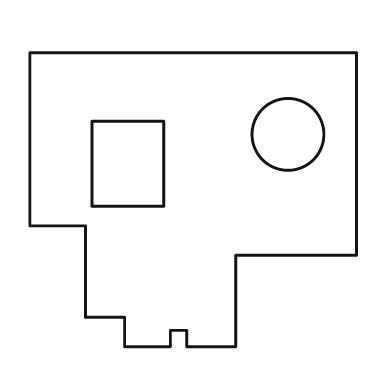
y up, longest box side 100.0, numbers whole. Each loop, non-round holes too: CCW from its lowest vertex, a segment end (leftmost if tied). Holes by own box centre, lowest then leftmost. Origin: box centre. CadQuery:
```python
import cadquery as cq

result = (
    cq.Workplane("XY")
    .moveTo(-21.0, -45.0)
    .lineTo(-7.0, -45.0)
    .lineTo(-7.0, -40.0)
    .lineTo(-2.0, -40.0)
    .lineTo(-2.0, -45.0)
    .lineTo(13.0, -45.0)
    .lineTo(13.0, -17.0)
    .lineTo(50.0, -17.0)
    .lineTo(50.0, 45.0)
    .lineTo(-50.0, 45.0)
    .lineTo(-50.0, -8.0)
    .lineTo(-33.0, -8.0)
    .lineTo(-33.0, -36.0)
    .lineTo(-21.0, -36.0)
    .close()
    .moveTo(-31.0, -2.0)
    .lineTo(-9.0, -2.0)
    .lineTo(-9.0, 24.0)
    .lineTo(-31.0, 24.0)
    .close()
    .moveTo(29.0, 20.0)
    .circle(11.0)
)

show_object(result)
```